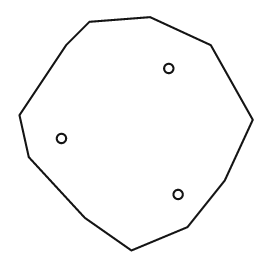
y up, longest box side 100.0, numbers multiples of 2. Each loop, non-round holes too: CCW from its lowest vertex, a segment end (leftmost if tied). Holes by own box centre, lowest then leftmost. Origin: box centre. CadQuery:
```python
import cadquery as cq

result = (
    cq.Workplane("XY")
    .moveTo(-2.0, -50.0)
    .lineTo(22.0, -40.0)
    .lineTo(38.0, -20.0)
    .lineTo(50.0, 6.0)
    .lineTo(32.0, 38.0)
    .lineTo(6.0, 50.0)
    .lineTo(-20.0, 48.0)
    .lineTo(-30.0, 38.0)
    .lineTo(-50.0, 8.0)
    .lineTo(-46.0, -10.0)
    .lineTo(-22.0, -36.0)
    .close()
    .moveTo(18.0, -26.0)
    .circle(2.0)
    .moveTo(-32.0, -2.0)
    .circle(2.0)
    .moveTo(14.0, 28.0)
    .circle(2.0)
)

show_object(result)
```